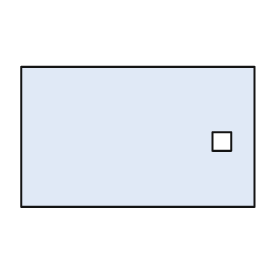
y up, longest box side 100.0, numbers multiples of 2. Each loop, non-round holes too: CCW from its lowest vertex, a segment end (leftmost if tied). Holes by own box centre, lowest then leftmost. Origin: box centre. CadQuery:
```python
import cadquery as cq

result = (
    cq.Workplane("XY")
    .moveTo(-50.0, -30.0)
    .lineTo(50.0, -30.0)
    .lineTo(50.0, 30.0)
    .lineTo(-50.0, 30.0)
    .close()
    .moveTo(32.0, -6.0)
    .lineTo(40.0, -6.0)
    .lineTo(40.0, 2.0)
    .lineTo(32.0, 2.0)
    .close()
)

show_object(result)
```